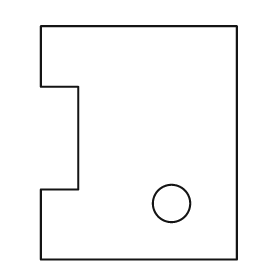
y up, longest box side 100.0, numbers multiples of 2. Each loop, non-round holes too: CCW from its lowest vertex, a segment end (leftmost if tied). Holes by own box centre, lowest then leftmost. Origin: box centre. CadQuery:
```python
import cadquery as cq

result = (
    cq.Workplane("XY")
    .moveTo(-42.0, -50.0)
    .lineTo(42.0, -50.0)
    .lineTo(42.0, 50.0)
    .lineTo(-42.0, 50.0)
    .lineTo(-42.0, 24.0)
    .lineTo(-26.0, 24.0)
    .lineTo(-26.0, -20.0)
    .lineTo(-42.0, -20.0)
    .close()
    .moveTo(14.0, -26.0)
    .circle(8.0)
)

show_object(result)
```